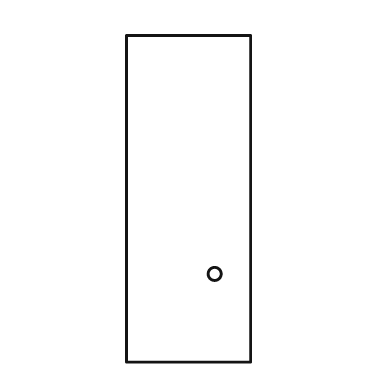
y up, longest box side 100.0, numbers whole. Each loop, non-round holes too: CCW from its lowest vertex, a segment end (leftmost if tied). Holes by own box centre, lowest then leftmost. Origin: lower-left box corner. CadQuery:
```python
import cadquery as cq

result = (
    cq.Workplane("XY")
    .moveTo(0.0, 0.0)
    .lineTo(38.0, 0.0)
    .lineTo(38.0, 100.0)
    .lineTo(0.0, 100.0)
    .close()
    .moveTo(27.0, 27.0)
    .circle(2.0)
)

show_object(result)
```